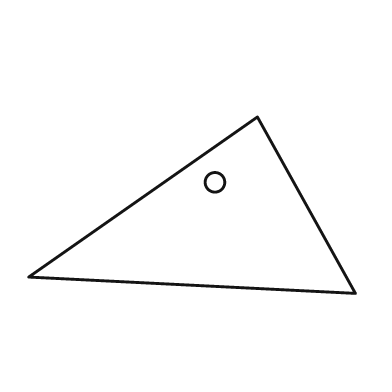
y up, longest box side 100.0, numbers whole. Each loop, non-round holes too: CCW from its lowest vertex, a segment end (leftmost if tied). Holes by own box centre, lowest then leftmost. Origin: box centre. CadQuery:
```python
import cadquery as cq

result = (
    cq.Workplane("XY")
    .moveTo(50.0, -27.0)
    .lineTo(20.0, 27.0)
    .lineTo(-50.0, -22.0)
    .close()
    .moveTo(7.0, 7.0)
    .circle(3.0)
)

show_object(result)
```